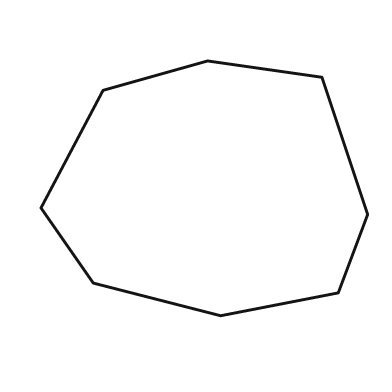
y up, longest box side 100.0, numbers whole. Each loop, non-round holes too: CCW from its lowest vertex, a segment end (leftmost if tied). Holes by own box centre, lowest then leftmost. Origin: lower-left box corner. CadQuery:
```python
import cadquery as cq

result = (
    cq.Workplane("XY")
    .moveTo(55.0, 0.0)
    .lineTo(91.0, 7.0)
    .lineTo(100.0, 31.0)
    .lineTo(86.0, 73.0)
    .lineTo(51.0, 78.0)
    .lineTo(19.0, 69.0)
    .lineTo(0.0, 33.0)
    .lineTo(16.0, 10.0)
    .close()
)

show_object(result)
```